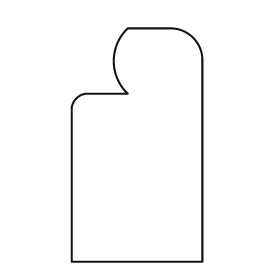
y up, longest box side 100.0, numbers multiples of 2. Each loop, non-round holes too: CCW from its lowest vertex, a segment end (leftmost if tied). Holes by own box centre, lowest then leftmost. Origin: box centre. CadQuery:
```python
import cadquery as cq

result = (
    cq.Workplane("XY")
    .moveTo(-28.0, -50.0)
    .lineTo(28.0, -50.0)
    .lineTo(28.0, 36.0)
    .threePointArc((24.0, 46.0), (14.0, 50.0))
    .lineTo(-4.0, 50.0)
    .threePointArc((-10.0, 36.0), (-4.0, 22.0))
    .lineTo(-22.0, 22.0)
    .threePointArc((-26.0, 20.0), (-28.0, 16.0))
    .close()
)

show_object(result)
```